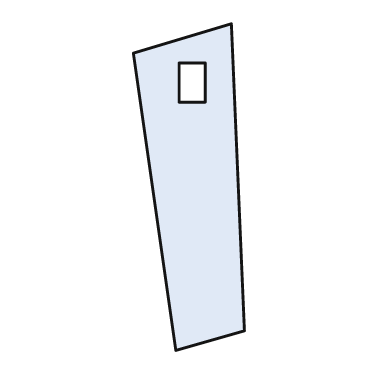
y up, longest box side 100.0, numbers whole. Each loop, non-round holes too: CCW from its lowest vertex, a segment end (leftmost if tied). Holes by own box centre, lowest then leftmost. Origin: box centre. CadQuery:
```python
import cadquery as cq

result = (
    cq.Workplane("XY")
    .moveTo(-4.0, -50.0)
    .lineTo(17.0, -44.0)
    .lineTo(13.0, 50.0)
    .lineTo(-17.0, 41.0)
    .close()
    .moveTo(-3.0, 26.0)
    .lineTo(5.0, 26.0)
    .lineTo(5.0, 38.0)
    .lineTo(-3.0, 38.0)
    .close()
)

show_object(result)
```